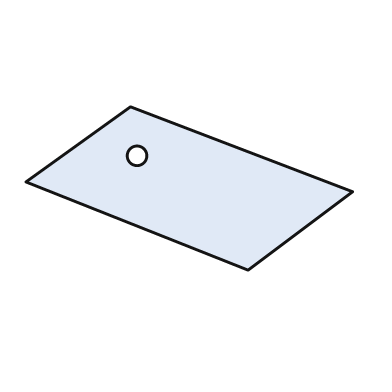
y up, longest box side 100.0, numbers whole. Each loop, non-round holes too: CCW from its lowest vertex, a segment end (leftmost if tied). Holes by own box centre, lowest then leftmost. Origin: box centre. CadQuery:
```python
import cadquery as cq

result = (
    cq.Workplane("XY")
    .moveTo(18.0, -25.0)
    .lineTo(50.0, -1.0)
    .lineTo(-18.0, 25.0)
    .lineTo(-50.0, 2.0)
    .close()
    .moveTo(-16.0, 10.0)
    .circle(3.0)
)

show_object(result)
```